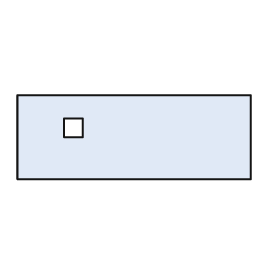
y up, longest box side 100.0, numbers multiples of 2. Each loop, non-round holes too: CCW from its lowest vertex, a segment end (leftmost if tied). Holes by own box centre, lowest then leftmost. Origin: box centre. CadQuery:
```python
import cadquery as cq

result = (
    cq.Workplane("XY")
    .moveTo(-50.0, -18.0)
    .lineTo(50.0, -18.0)
    .lineTo(50.0, 18.0)
    .lineTo(-50.0, 18.0)
    .close()
    .moveTo(-30.0, 0.0)
    .lineTo(-22.0, 0.0)
    .lineTo(-22.0, 8.0)
    .lineTo(-30.0, 8.0)
    .close()
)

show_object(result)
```